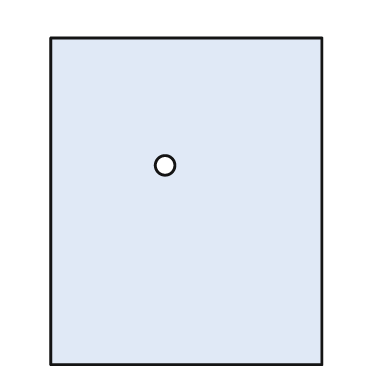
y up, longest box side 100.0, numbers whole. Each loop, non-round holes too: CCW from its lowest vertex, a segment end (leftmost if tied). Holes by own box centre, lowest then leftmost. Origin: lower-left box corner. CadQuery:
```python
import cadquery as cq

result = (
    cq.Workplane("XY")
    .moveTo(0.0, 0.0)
    .lineTo(83.0, 0.0)
    .lineTo(83.0, 100.0)
    .lineTo(0.0, 100.0)
    .close()
    .moveTo(35.0, 61.0)
    .circle(3.0)
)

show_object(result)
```